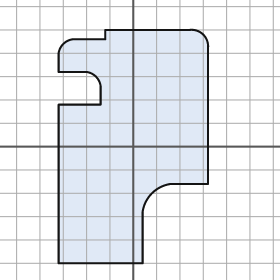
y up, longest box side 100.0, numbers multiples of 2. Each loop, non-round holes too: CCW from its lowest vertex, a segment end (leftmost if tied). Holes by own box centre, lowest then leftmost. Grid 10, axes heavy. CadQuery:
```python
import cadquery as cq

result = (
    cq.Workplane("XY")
    .moveTo(-32.0, -50.0)
    .lineTo(4.0, -50.0)
    .lineTo(4.0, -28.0)
    .threePointArc((8.0, -20.0), (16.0, -16.0))
    .lineTo(32.0, -16.0)
    .lineTo(32.0, 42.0)
    .threePointArc((30.0, 48.0), (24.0, 50.0))
    .lineTo(-12.0, 50.0)
    .lineTo(-12.0, 46.0)
    .lineTo(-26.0, 46.0)
    .threePointArc((-30.0, 44.0), (-32.0, 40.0))
    .lineTo(-32.0, 32.0)
    .lineTo(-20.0, 32.0)
    .threePointArc((-16.0, 30.0), (-14.0, 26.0))
    .lineTo(-14.0, 18.0)
    .lineTo(-32.0, 18.0)
    .close()
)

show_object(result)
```